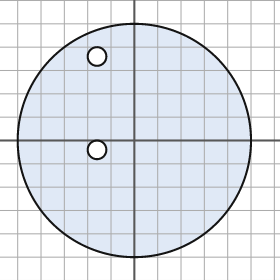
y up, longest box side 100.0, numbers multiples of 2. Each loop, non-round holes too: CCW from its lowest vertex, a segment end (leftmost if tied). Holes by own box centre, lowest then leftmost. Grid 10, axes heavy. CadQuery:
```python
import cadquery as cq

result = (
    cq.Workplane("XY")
    .moveTo(0.0, 0.0)
    .circle(50.0)
    .moveTo(-16.0, -4.0)
    .circle(4.0)
    .moveTo(-16.0, 36.0)
    .circle(4.0)
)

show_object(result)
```